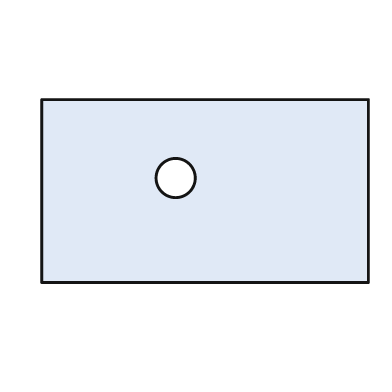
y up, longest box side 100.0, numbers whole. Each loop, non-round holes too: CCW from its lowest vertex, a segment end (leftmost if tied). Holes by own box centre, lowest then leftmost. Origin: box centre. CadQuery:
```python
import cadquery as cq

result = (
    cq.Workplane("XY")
    .moveTo(-50.0, -28.0)
    .lineTo(50.0, -28.0)
    .lineTo(50.0, 28.0)
    .lineTo(-50.0, 28.0)
    .close()
    .moveTo(-9.0, 4.0)
    .circle(6.0)
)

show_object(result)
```